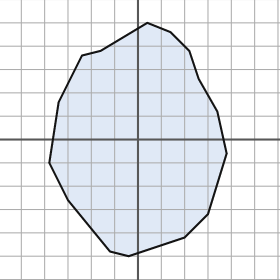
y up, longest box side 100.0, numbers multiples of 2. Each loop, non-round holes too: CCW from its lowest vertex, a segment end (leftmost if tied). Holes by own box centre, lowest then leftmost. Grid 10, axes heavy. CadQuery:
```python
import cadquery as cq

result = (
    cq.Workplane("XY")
    .moveTo(-4.0, -50.0)
    .lineTo(20.0, -42.0)
    .lineTo(30.0, -32.0)
    .lineTo(38.0, -6.0)
    .lineTo(34.0, 12.0)
    .lineTo(26.0, 26.0)
    .lineTo(22.0, 38.0)
    .lineTo(14.0, 46.0)
    .lineTo(4.0, 50.0)
    .lineTo(-16.0, 38.0)
    .lineTo(-24.0, 36.0)
    .lineTo(-34.0, 16.0)
    .lineTo(-38.0, -10.0)
    .lineTo(-30.0, -26.0)
    .lineTo(-12.0, -48.0)
    .close()
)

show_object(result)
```